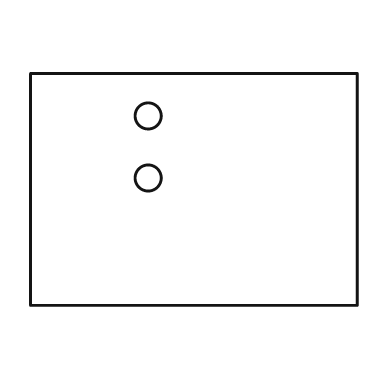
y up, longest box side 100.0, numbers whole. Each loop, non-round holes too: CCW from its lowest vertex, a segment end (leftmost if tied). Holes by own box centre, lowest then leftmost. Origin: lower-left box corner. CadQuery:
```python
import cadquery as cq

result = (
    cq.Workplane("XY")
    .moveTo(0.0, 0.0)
    .lineTo(100.0, 0.0)
    .lineTo(100.0, 71.0)
    .lineTo(0.0, 71.0)
    .close()
    .moveTo(36.0, 39.0)
    .circle(4.0)
    .moveTo(36.0, 58.0)
    .circle(4.0)
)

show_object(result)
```